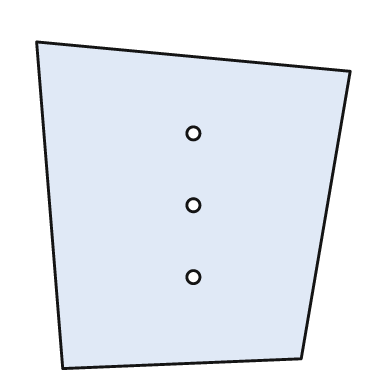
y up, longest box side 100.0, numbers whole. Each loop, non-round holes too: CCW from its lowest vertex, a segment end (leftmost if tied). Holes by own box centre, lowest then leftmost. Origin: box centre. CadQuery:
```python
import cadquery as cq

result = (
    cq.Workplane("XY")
    .moveTo(-40.0, -50.0)
    .lineTo(33.0, -47.0)
    .lineTo(48.0, 41.0)
    .lineTo(-48.0, 50.0)
    .close()
    .moveTo(0.0, -22.0)
    .circle(2.0)
    .moveTo(0.0, 0.0)
    .circle(2.0)
    .moveTo(0.0, 22.0)
    .circle(2.0)
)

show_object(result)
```